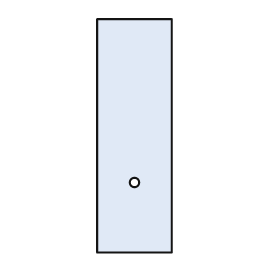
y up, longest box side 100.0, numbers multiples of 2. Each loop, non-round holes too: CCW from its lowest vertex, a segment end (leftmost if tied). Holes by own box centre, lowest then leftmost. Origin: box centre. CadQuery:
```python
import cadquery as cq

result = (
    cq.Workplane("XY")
    .moveTo(-16.0, -50.0)
    .lineTo(16.0, -50.0)
    .lineTo(16.0, 50.0)
    .lineTo(-16.0, 50.0)
    .close()
    .moveTo(0.0, -20.0)
    .circle(2.0)
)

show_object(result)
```